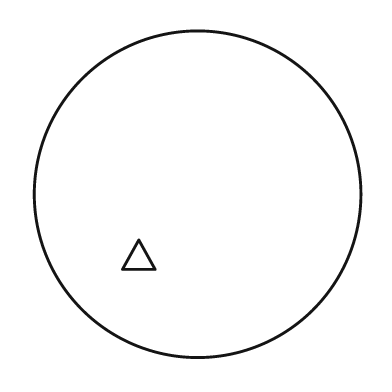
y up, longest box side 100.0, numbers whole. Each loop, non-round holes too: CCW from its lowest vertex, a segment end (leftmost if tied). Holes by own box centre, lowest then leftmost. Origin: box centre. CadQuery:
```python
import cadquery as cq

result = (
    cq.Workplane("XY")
    .moveTo(0.0, 0.0)
    .circle(50.0)
    .moveTo(-23.0, -23.0)
    .lineTo(-13.0, -23.0)
    .lineTo(-18.0, -14.0)
    .close()
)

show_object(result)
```